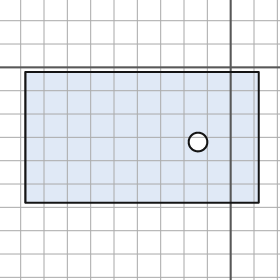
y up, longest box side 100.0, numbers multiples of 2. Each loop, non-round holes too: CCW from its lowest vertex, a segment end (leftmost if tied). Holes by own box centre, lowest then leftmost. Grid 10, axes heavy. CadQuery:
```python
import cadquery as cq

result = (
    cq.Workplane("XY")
    .moveTo(-88.0, -58.0)
    .lineTo(12.0, -58.0)
    .lineTo(12.0, -2.0)
    .lineTo(-88.0, -2.0)
    .close()
    .moveTo(-14.0, -32.0)
    .circle(4.0)
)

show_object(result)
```